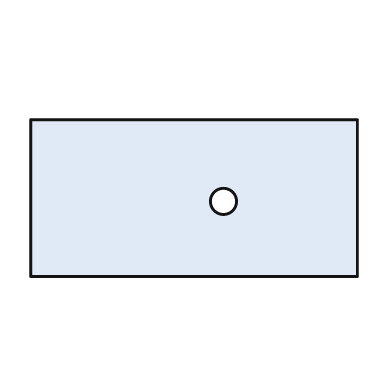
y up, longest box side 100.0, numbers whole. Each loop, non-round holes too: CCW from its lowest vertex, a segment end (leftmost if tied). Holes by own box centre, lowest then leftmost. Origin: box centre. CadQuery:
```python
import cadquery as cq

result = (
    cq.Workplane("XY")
    .moveTo(-50.0, -24.0)
    .lineTo(50.0, -24.0)
    .lineTo(50.0, 24.0)
    .lineTo(-50.0, 24.0)
    .close()
    .moveTo(9.0, -1.0)
    .circle(4.0)
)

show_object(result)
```